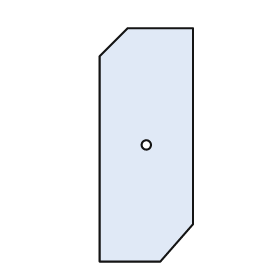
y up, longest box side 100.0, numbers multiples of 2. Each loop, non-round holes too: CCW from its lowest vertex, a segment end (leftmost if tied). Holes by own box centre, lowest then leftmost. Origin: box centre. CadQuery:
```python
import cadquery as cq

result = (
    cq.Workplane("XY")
    .moveTo(-20.0, -50.0)
    .lineTo(6.0, -50.0)
    .lineTo(20.0, -34.0)
    .lineTo(20.0, 50.0)
    .lineTo(-8.0, 50.0)
    .lineTo(-20.0, 38.0)
    .close()
    .moveTo(0.0, 0.0)
    .circle(2.0)
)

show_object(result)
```